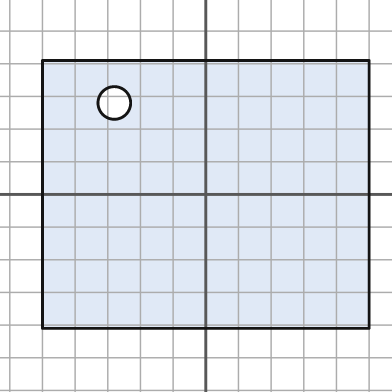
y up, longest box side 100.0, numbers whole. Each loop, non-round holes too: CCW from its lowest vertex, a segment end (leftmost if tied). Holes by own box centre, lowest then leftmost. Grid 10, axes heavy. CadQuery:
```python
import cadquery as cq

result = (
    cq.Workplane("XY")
    .moveTo(-50.0, -41.0)
    .lineTo(50.0, -41.0)
    .lineTo(50.0, 41.0)
    .lineTo(-50.0, 41.0)
    .close()
    .moveTo(-28.0, 28.0)
    .circle(5.0)
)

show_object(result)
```